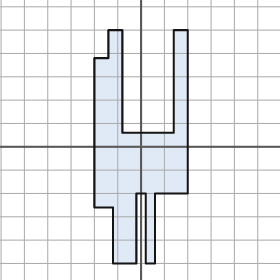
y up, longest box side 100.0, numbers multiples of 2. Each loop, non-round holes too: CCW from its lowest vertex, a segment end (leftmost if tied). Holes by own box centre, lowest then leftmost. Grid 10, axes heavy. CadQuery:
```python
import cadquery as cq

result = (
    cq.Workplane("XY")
    .moveTo(-12.0, -50.0)
    .lineTo(-2.0, -50.0)
    .lineTo(-2.0, -20.0)
    .lineTo(2.0, -20.0)
    .lineTo(2.0, -50.0)
    .lineTo(6.0, -50.0)
    .lineTo(6.0, -20.0)
    .lineTo(20.0, -20.0)
    .lineTo(20.0, 50.0)
    .lineTo(14.0, 50.0)
    .lineTo(14.0, 6.0)
    .lineTo(-8.0, 6.0)
    .lineTo(-8.0, 50.0)
    .lineTo(-14.0, 50.0)
    .lineTo(-14.0, 38.0)
    .lineTo(-20.0, 38.0)
    .lineTo(-20.0, -26.0)
    .lineTo(-12.0, -26.0)
    .close()
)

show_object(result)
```